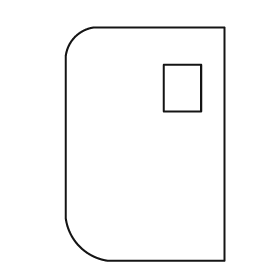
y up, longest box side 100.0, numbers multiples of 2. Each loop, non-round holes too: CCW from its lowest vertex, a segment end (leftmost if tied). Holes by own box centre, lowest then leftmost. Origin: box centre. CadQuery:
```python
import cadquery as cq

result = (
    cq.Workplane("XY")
    .moveTo(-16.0, -50.0)
    .lineTo(34.0, -50.0)
    .lineTo(34.0, 50.0)
    .lineTo(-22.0, 50.0)
    .threePointArc((-30.0, 46.0), (-34.0, 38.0))
    .lineTo(-34.0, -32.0)
    .threePointArc((-28.0, -44.0), (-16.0, -50.0))
    .close()
    .moveTo(8.0, 14.0)
    .lineTo(24.0, 14.0)
    .lineTo(24.0, 34.0)
    .lineTo(8.0, 34.0)
    .close()
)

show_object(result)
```